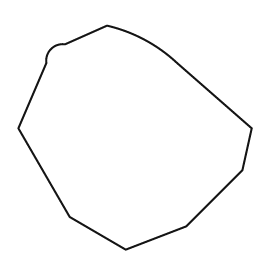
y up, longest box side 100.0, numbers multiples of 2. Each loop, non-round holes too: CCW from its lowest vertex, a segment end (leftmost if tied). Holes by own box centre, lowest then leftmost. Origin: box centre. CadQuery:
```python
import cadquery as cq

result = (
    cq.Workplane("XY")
    .moveTo(-4.0, -48.0)
    .lineTo(22.0, -38.0)
    .lineTo(46.0, -14.0)
    .lineTo(50.0, 4.0)
    .lineTo(18.0, 32.0)
    .threePointArc((4.0, 42.0), (-12.0, 48.0))
    .lineTo(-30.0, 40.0)
    .threePointArc((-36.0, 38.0), (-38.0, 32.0))
    .lineTo(-50.0, 4.0)
    .lineTo(-28.0, -34.0)
    .close()
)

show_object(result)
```